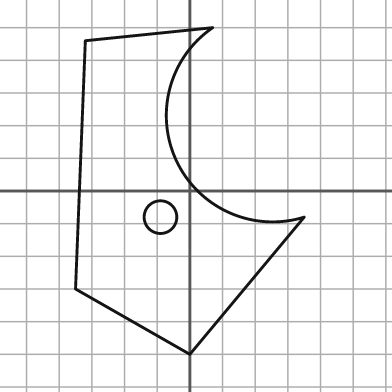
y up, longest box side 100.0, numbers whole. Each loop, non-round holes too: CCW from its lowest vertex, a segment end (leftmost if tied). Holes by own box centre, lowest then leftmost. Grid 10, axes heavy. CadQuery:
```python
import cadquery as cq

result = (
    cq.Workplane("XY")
    .moveTo(0.0, -50.0)
    .lineTo(35.0, -8.0)
    .threePointArc((-4.0, 9.0), (7.0, 50.0))
    .lineTo(-32.0, 46.0)
    .lineTo(-35.0, -30.0)
    .close()
    .moveTo(-9.0, -8.0)
    .circle(5.0)
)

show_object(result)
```